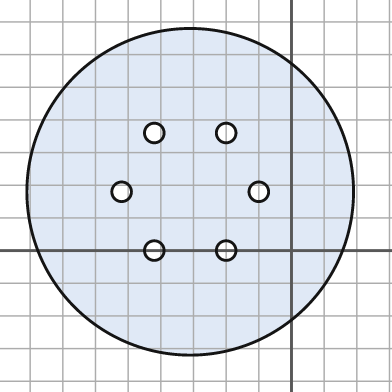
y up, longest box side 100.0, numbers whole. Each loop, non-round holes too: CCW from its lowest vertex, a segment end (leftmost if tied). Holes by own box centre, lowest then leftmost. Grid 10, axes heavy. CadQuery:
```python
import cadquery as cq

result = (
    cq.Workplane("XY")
    .moveTo(-31.0, 18.0)
    .circle(50.0)
    .moveTo(-42.0, 0.0)
    .circle(3.0)
    .moveTo(-20.0, 0.0)
    .circle(3.0)
    .moveTo(-52.0, 18.0)
    .circle(3.0)
    .moveTo(-10.0, 18.0)
    .circle(3.0)
    .moveTo(-42.0, 36.0)
    .circle(3.0)
    .moveTo(-20.0, 36.0)
    .circle(3.0)
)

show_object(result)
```